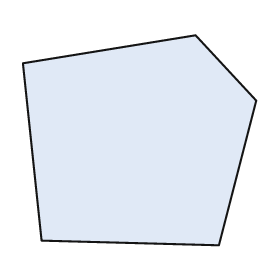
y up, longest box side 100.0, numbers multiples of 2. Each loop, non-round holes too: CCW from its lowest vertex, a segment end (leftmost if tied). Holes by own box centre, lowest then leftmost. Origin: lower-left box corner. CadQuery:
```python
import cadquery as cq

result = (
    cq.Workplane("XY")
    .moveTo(84.0, 0.0)
    .lineTo(100.0, 62.0)
    .lineTo(74.0, 90.0)
    .lineTo(0.0, 78.0)
    .lineTo(8.0, 2.0)
    .close()
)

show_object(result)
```